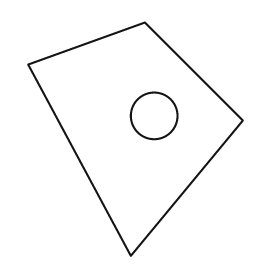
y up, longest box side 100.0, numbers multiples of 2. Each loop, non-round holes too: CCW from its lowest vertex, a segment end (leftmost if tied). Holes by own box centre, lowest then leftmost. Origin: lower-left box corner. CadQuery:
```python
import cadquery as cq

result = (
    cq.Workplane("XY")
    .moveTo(44.0, 0.0)
    .lineTo(92.0, 58.0)
    .lineTo(50.0, 100.0)
    .lineTo(0.0, 82.0)
    .close()
    .moveTo(54.0, 60.0)
    .circle(10.0)
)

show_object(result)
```